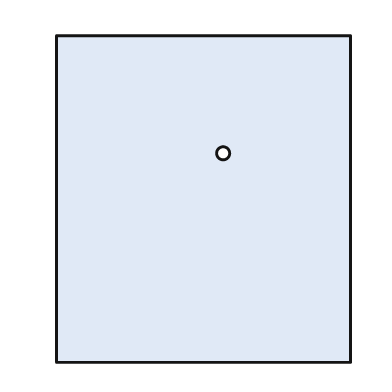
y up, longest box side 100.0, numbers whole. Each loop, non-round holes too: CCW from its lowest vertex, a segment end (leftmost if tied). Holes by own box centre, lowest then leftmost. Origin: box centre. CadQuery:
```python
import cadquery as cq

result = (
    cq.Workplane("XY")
    .moveTo(-45.0, -50.0)
    .lineTo(45.0, -50.0)
    .lineTo(45.0, 50.0)
    .lineTo(-45.0, 50.0)
    .close()
    .moveTo(6.0, 14.0)
    .circle(2.0)
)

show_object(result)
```